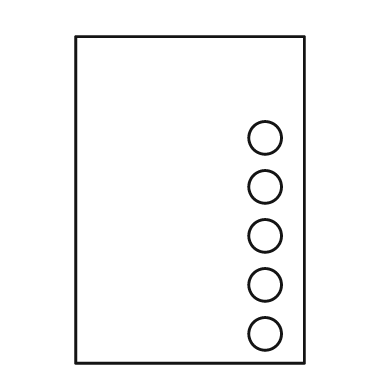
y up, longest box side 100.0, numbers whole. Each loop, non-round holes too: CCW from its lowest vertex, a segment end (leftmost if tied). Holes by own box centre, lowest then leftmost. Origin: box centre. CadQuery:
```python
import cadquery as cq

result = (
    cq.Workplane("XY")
    .moveTo(-35.0, -50.0)
    .lineTo(35.0, -50.0)
    .lineTo(35.0, 50.0)
    .lineTo(-35.0, 50.0)
    .close()
    .moveTo(23.0, -41.0)
    .circle(5.0)
    .moveTo(23.0, -26.0)
    .circle(5.0)
    .moveTo(23.0, -11.0)
    .circle(5.0)
    .moveTo(23.0, 4.0)
    .circle(5.0)
    .moveTo(23.0, 19.0)
    .circle(5.0)
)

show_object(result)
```